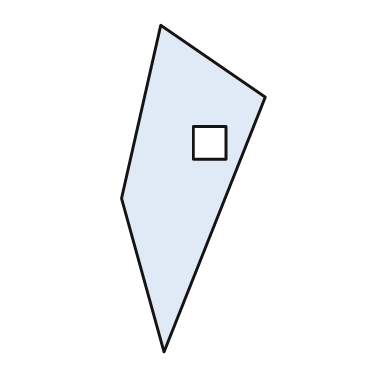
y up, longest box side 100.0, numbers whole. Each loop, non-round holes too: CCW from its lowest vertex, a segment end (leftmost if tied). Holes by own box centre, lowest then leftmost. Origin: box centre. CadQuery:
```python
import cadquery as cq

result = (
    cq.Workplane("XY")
    .moveTo(-9.0, -50.0)
    .lineTo(22.0, 28.0)
    .lineTo(-10.0, 50.0)
    .lineTo(-22.0, -3.0)
    .close()
    .moveTo(0.0, 9.0)
    .lineTo(10.0, 9.0)
    .lineTo(10.0, 19.0)
    .lineTo(0.0, 19.0)
    .close()
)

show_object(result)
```